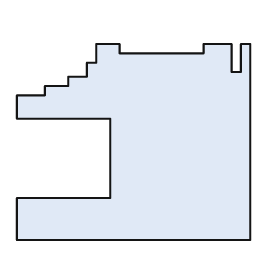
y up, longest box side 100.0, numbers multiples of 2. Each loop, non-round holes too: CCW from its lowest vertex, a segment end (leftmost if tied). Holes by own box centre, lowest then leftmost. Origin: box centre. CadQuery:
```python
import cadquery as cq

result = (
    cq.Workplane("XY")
    .moveTo(-50.0, -42.0)
    .lineTo(50.0, -42.0)
    .lineTo(50.0, 42.0)
    .lineTo(46.0, 42.0)
    .lineTo(46.0, 30.0)
    .lineTo(42.0, 30.0)
    .lineTo(42.0, 42.0)
    .lineTo(30.0, 42.0)
    .lineTo(30.0, 38.0)
    .lineTo(-6.0, 38.0)
    .lineTo(-6.0, 42.0)
    .lineTo(-16.0, 42.0)
    .lineTo(-16.0, 34.0)
    .lineTo(-20.0, 34.0)
    .lineTo(-20.0, 28.0)
    .lineTo(-28.0, 28.0)
    .lineTo(-28.0, 24.0)
    .lineTo(-38.0, 24.0)
    .lineTo(-38.0, 20.0)
    .lineTo(-50.0, 20.0)
    .lineTo(-50.0, 10.0)
    .lineTo(-10.0, 10.0)
    .lineTo(-10.0, -24.0)
    .lineTo(-50.0, -24.0)
    .close()
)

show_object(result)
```